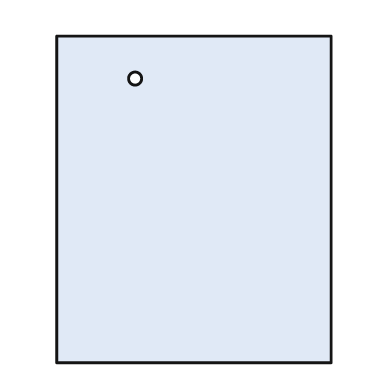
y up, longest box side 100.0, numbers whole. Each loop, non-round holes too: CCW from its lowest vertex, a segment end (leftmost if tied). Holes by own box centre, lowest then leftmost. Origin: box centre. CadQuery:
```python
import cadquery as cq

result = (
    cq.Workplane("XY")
    .moveTo(-42.0, -50.0)
    .lineTo(42.0, -50.0)
    .lineTo(42.0, 50.0)
    .lineTo(-42.0, 50.0)
    .close()
    .moveTo(-18.0, 37.0)
    .circle(2.0)
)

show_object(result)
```